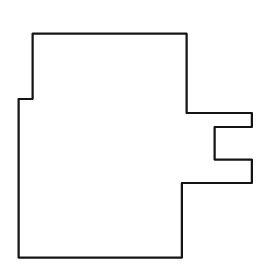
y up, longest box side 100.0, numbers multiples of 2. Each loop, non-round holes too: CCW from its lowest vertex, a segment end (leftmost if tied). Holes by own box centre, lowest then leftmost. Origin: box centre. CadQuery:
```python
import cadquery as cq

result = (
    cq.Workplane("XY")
    .moveTo(-50.0, -48.0)
    .lineTo(20.0, -48.0)
    .lineTo(20.0, -16.0)
    .lineTo(50.0, -16.0)
    .lineTo(50.0, -6.0)
    .lineTo(34.0, -6.0)
    .lineTo(34.0, 8.0)
    .lineTo(50.0, 8.0)
    .lineTo(50.0, 14.0)
    .lineTo(22.0, 14.0)
    .lineTo(22.0, 48.0)
    .lineTo(-44.0, 48.0)
    .lineTo(-44.0, 20.0)
    .lineTo(-50.0, 20.0)
    .close()
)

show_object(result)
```